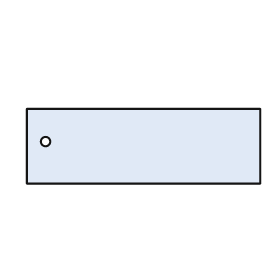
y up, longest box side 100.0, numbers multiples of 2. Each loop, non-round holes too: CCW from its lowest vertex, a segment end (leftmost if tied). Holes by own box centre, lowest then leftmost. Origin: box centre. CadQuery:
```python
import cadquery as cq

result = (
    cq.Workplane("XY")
    .moveTo(-50.0, -16.0)
    .lineTo(50.0, -16.0)
    .lineTo(50.0, 16.0)
    .lineTo(-50.0, 16.0)
    .close()
    .moveTo(-42.0, 2.0)
    .circle(2.0)
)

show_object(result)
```